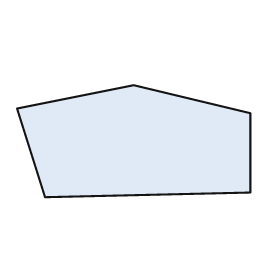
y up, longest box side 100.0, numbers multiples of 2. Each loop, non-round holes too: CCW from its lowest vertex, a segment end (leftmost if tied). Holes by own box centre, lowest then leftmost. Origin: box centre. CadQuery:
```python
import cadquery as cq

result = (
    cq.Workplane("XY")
    .moveTo(-38.0, -24.0)
    .lineTo(50.0, -22.0)
    .lineTo(50.0, 12.0)
    .lineTo(0.0, 24.0)
    .lineTo(-50.0, 14.0)
    .close()
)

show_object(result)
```